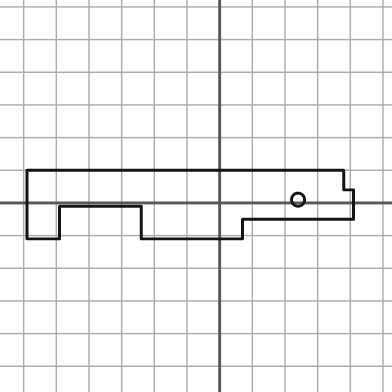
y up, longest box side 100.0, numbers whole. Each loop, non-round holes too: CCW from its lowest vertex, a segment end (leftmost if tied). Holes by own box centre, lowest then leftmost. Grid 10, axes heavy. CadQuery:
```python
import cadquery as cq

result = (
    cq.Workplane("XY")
    .moveTo(-59.0, -11.0)
    .lineTo(-49.0, -11.0)
    .lineTo(-49.0, -1.0)
    .lineTo(-24.0, -1.0)
    .lineTo(-24.0, -11.0)
    .lineTo(7.0, -11.0)
    .lineTo(7.0, -5.0)
    .lineTo(41.0, -5.0)
    .lineTo(41.0, 4.0)
    .lineTo(38.0, 4.0)
    .lineTo(38.0, 10.0)
    .lineTo(-59.0, 10.0)
    .close()
    .moveTo(24.0, 1.0)
    .circle(2.0)
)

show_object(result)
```